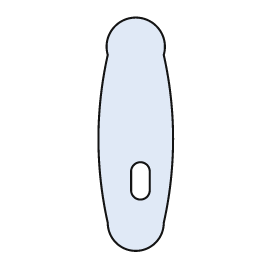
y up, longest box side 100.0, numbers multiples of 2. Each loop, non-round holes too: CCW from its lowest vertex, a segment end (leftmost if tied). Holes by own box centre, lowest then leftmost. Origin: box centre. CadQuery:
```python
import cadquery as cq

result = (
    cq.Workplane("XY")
    .moveTo(-12.0, -38.0)
    .threePointArc((0.0, -50.0), (12.0, -38.0))
    .threePointArc((16.0, -2.0), (12.0, 34.0))
    .threePointArc((0.0, 50.0), (-12.0, 34.0))
    .threePointArc((-16.0, -2.0), (-12.0, -38.0))
    .close()
    .moveTo(-2.0, -24.0)
    .threePointArc((2.0, -28.0), (6.0, -24.0))
    .lineTo(6.0, -16.0)
    .threePointArc((2.0, -12.0), (-2.0, -16.0))
    .close()
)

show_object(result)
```